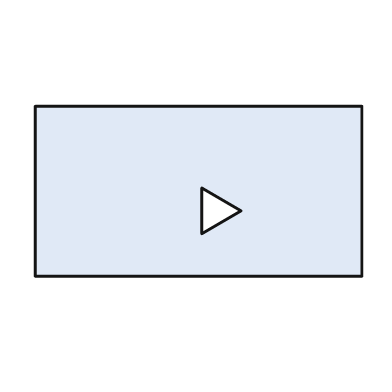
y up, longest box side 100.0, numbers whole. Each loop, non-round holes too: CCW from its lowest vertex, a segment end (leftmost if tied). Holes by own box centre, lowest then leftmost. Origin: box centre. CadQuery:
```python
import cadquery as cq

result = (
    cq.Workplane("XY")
    .moveTo(-50.0, -26.0)
    .lineTo(50.0, -26.0)
    .lineTo(50.0, 26.0)
    .lineTo(-50.0, 26.0)
    .close()
    .moveTo(1.0, -13.0)
    .lineTo(13.0, -6.0)
    .lineTo(1.0, 1.0)
    .close()
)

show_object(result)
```